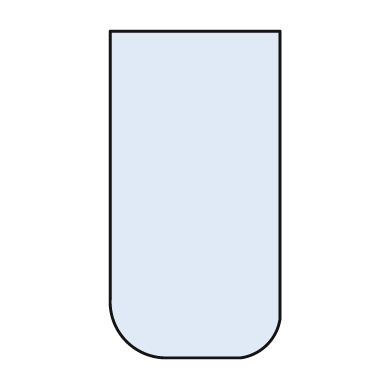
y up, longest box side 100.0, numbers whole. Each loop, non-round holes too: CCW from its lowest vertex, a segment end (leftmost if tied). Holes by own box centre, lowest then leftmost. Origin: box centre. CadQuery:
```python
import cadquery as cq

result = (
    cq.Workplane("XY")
    .moveTo(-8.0, -50.0)
    .lineTo(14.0, -50.0)
    .threePointArc((22.0, -46.0), (26.0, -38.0))
    .lineTo(26.0, 50.0)
    .lineTo(-26.0, 50.0)
    .lineTo(-26.0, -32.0)
    .threePointArc((-21.0, -45.0), (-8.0, -50.0))
    .close()
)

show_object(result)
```